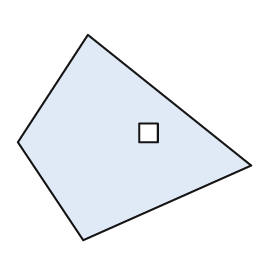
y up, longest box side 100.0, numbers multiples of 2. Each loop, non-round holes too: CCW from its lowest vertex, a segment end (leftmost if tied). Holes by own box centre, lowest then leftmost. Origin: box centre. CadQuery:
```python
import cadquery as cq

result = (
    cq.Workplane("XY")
    .moveTo(-22.0, -44.0)
    .lineTo(50.0, -12.0)
    .lineTo(-20.0, 44.0)
    .lineTo(-50.0, -2.0)
    .close()
    .moveTo(2.0, -2.0)
    .lineTo(10.0, -2.0)
    .lineTo(10.0, 6.0)
    .lineTo(2.0, 6.0)
    .close()
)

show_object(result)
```